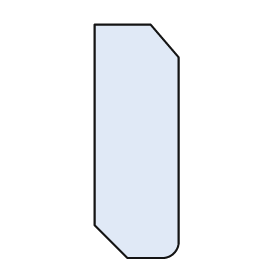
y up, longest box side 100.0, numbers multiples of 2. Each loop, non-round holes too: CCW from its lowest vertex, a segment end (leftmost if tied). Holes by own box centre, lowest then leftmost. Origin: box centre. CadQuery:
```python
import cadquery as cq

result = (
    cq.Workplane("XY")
    .moveTo(-4.0, -50.0)
    .lineTo(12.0, -50.0)
    .threePointArc((16.0, -48.0), (18.0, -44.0))
    .lineTo(18.0, 36.0)
    .lineTo(6.0, 50.0)
    .lineTo(-18.0, 50.0)
    .lineTo(-18.0, -36.0)
    .close()
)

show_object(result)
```